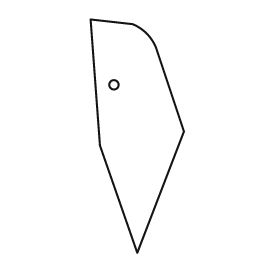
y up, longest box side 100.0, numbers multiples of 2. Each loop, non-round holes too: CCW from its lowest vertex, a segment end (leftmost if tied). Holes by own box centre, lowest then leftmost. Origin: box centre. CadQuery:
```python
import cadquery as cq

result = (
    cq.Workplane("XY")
    .moveTo(0.0, -50.0)
    .lineTo(20.0, 2.0)
    .lineTo(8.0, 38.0)
    .threePointArc((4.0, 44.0), (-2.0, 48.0))
    .lineTo(-20.0, 50.0)
    .lineTo(-16.0, -4.0)
    .close()
    .moveTo(-10.0, 22.0)
    .circle(2.0)
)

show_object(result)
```